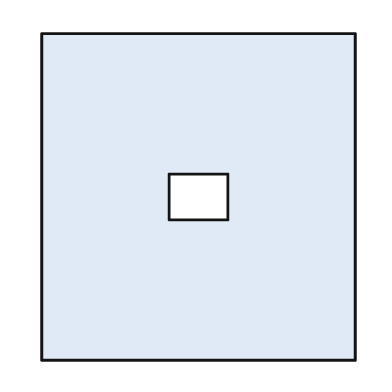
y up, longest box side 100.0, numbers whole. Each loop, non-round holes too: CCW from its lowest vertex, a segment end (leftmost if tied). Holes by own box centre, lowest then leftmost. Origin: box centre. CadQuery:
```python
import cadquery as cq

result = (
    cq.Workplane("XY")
    .moveTo(-48.0, -50.0)
    .lineTo(48.0, -50.0)
    .lineTo(48.0, 50.0)
    .lineTo(-48.0, 50.0)
    .close()
    .moveTo(-9.0, -7.0)
    .lineTo(9.0, -7.0)
    .lineTo(9.0, 7.0)
    .lineTo(-9.0, 7.0)
    .close()
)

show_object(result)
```